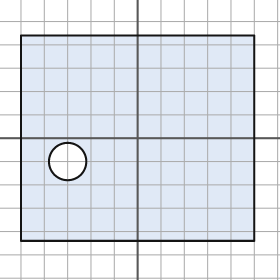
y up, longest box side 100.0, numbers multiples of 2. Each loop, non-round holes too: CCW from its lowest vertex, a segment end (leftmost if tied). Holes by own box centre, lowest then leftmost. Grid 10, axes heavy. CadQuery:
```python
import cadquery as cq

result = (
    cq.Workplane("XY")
    .moveTo(-50.0, -44.0)
    .lineTo(50.0, -44.0)
    .lineTo(50.0, 44.0)
    .lineTo(-50.0, 44.0)
    .close()
    .moveTo(-30.0, -10.0)
    .circle(8.0)
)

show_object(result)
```